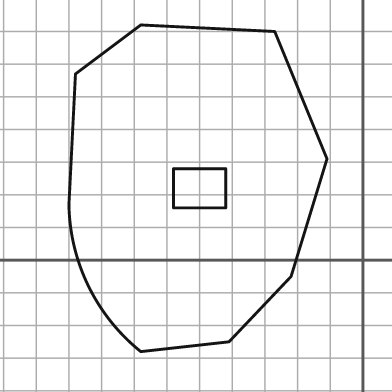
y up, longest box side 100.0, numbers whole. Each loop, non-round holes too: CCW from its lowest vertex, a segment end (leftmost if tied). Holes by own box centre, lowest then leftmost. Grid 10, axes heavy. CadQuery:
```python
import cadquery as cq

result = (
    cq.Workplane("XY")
    .moveTo(-68.0, -28.0)
    .lineTo(-41.0, -25.0)
    .lineTo(-22.0, -5.0)
    .lineTo(-11.0, 31.0)
    .lineTo(-27.0, 70.0)
    .lineTo(-68.0, 72.0)
    .lineTo(-88.0, 57.0)
    .lineTo(-90.0, 17.0)
    .threePointArc((-84.0, -8.0), (-68.0, -28.0))
    .close()
    .moveTo(-58.0, 16.0)
    .lineTo(-42.0, 16.0)
    .lineTo(-42.0, 28.0)
    .lineTo(-58.0, 28.0)
    .close()
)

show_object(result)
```